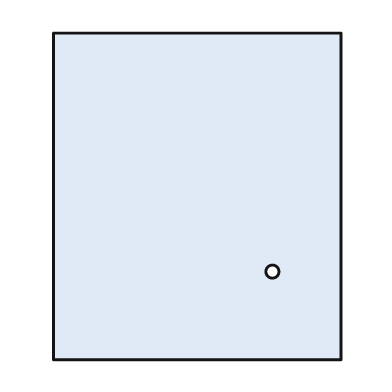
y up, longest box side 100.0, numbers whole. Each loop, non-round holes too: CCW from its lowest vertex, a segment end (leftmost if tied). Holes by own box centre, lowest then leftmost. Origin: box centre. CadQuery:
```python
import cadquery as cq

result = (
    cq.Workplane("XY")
    .moveTo(-44.0, -50.0)
    .lineTo(44.0, -50.0)
    .lineTo(44.0, 50.0)
    .lineTo(-44.0, 50.0)
    .close()
    .moveTo(23.0, -23.0)
    .circle(2.0)
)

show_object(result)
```